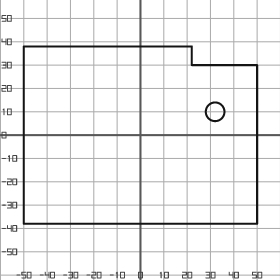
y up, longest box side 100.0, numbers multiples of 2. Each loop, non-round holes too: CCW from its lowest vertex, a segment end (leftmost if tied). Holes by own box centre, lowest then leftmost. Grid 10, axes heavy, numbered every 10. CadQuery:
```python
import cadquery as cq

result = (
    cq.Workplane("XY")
    .moveTo(-50.0, -38.0)
    .lineTo(50.0, -38.0)
    .lineTo(50.0, 30.0)
    .lineTo(22.0, 30.0)
    .lineTo(22.0, 38.0)
    .lineTo(-50.0, 38.0)
    .close()
    .moveTo(32.0, 10.0)
    .circle(4.0)
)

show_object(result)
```